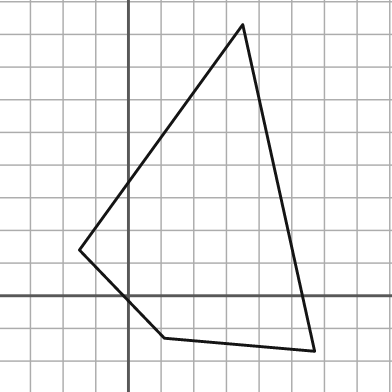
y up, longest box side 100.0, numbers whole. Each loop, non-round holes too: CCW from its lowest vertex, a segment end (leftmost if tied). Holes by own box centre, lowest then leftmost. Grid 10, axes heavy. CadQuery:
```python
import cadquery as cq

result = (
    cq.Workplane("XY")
    .moveTo(57.0, -17.0)
    .lineTo(35.0, 83.0)
    .lineTo(-15.0, 14.0)
    .lineTo(11.0, -13.0)
    .close()
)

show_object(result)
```